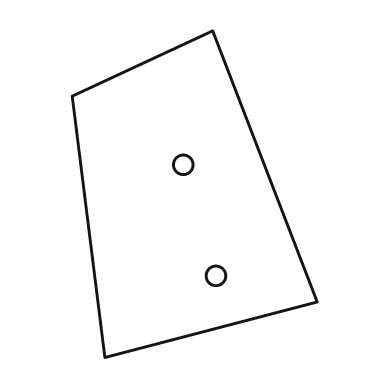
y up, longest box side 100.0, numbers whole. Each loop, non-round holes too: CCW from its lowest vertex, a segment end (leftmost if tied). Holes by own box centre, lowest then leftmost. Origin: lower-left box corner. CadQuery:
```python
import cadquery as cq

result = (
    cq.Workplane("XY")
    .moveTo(10.0, 0.0)
    .lineTo(75.0, 17.0)
    .lineTo(43.0, 100.0)
    .lineTo(0.0, 80.0)
    .close()
    .moveTo(44.0, 25.0)
    .circle(3.0)
    .moveTo(34.0, 59.0)
    .circle(3.0)
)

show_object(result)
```